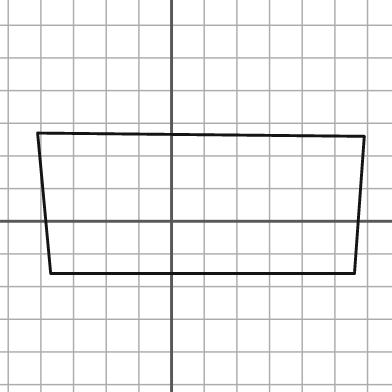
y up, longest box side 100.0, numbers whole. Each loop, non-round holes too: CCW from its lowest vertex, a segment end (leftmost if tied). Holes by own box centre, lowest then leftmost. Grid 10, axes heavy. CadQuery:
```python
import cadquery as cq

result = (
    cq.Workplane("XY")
    .moveTo(-37.0, -16.0)
    .lineTo(56.0, -16.0)
    .lineTo(59.0, 26.0)
    .lineTo(-41.0, 27.0)
    .close()
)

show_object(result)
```